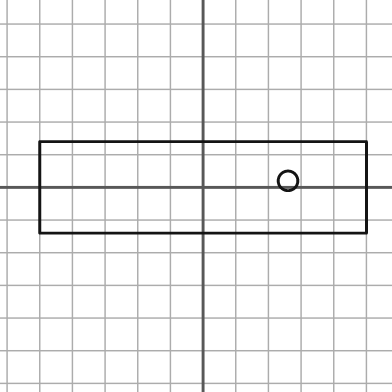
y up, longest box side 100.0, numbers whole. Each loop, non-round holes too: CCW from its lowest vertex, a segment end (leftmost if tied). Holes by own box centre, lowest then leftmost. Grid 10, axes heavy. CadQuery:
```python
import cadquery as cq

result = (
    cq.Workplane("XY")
    .moveTo(-50.0, -14.0)
    .lineTo(50.0, -14.0)
    .lineTo(50.0, 14.0)
    .lineTo(-50.0, 14.0)
    .close()
    .moveTo(26.0, 2.0)
    .circle(3.0)
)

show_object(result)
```